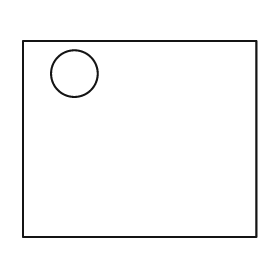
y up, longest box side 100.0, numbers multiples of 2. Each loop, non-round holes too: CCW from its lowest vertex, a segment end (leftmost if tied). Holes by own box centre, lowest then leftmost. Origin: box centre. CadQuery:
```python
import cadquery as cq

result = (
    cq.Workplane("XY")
    .moveTo(-50.0, -42.0)
    .lineTo(50.0, -42.0)
    .lineTo(50.0, 42.0)
    .lineTo(-50.0, 42.0)
    .close()
    .moveTo(-28.0, 28.0)
    .circle(10.0)
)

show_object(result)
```